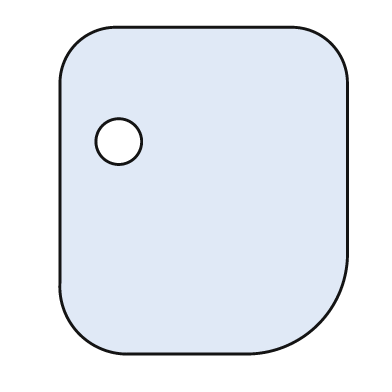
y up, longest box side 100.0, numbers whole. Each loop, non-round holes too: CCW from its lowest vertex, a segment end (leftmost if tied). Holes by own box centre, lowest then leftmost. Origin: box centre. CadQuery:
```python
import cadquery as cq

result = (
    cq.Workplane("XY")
    .moveTo(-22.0, -50.0)
    .lineTo(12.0, -50.0)
    .threePointArc((35.0, -41.0), (44.0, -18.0))
    .lineTo(44.0, 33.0)
    .threePointArc((39.0, 45.0), (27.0, 50.0))
    .lineTo(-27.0, 50.0)
    .threePointArc((-39.0, 45.0), (-44.0, 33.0))
    .lineTo(-44.0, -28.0)
    .threePointArc((-38.0, -44.0), (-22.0, -50.0))
    .close()
    .moveTo(-26.0, 15.0)
    .circle(7.0)
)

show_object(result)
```